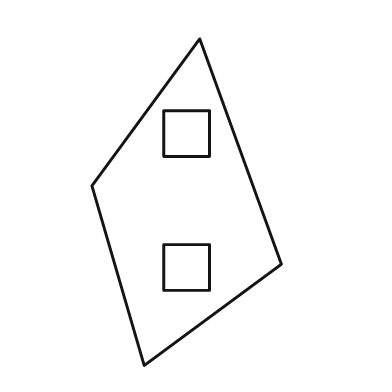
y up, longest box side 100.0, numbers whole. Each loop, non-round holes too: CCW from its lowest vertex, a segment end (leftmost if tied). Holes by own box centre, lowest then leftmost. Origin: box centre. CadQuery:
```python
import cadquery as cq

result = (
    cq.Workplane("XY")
    .moveTo(-13.0, -50.0)
    .lineTo(29.0, -19.0)
    .lineTo(4.0, 50.0)
    .lineTo(-29.0, 5.0)
    .close()
    .moveTo(-7.0, -27.0)
    .lineTo(7.0, -27.0)
    .lineTo(7.0, -13.0)
    .lineTo(-7.0, -13.0)
    .close()
    .moveTo(-7.0, 14.0)
    .lineTo(7.0, 14.0)
    .lineTo(7.0, 28.0)
    .lineTo(-7.0, 28.0)
    .close()
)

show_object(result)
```